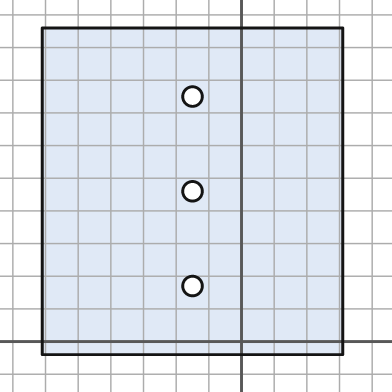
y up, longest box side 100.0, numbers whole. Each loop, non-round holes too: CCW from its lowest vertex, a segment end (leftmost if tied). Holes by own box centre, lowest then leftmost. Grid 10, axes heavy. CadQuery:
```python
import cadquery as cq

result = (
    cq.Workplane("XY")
    .moveTo(-61.0, -4.0)
    .lineTo(31.0, -4.0)
    .lineTo(31.0, 96.0)
    .lineTo(-61.0, 96.0)
    .close()
    .moveTo(-15.0, 17.0)
    .circle(3.0)
    .moveTo(-15.0, 46.0)
    .circle(3.0)
    .moveTo(-15.0, 75.0)
    .circle(3.0)
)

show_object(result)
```